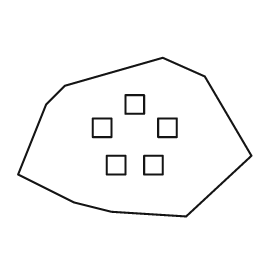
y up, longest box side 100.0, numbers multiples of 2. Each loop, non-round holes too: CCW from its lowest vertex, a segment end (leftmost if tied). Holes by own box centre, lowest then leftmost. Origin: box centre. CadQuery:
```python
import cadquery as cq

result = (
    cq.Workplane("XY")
    .moveTo(22.0, -34.0)
    .lineTo(50.0, -8.0)
    .lineTo(30.0, 26.0)
    .lineTo(12.0, 34.0)
    .lineTo(-30.0, 22.0)
    .lineTo(-38.0, 14.0)
    .lineTo(-50.0, -16.0)
    .lineTo(-26.0, -28.0)
    .lineTo(-10.0, -32.0)
    .close()
    .moveTo(-12.0, -16.0)
    .lineTo(-4.0, -16.0)
    .lineTo(-4.0, -8.0)
    .lineTo(-12.0, -8.0)
    .close()
    .moveTo(4.0, -16.0)
    .lineTo(12.0, -16.0)
    .lineTo(12.0, -8.0)
    .lineTo(4.0, -8.0)
    .close()
    .moveTo(-18.0, 0.0)
    .lineTo(-10.0, 0.0)
    .lineTo(-10.0, 8.0)
    .lineTo(-18.0, 8.0)
    .close()
    .moveTo(10.0, 0.0)
    .lineTo(18.0, 0.0)
    .lineTo(18.0, 8.0)
    .lineTo(10.0, 8.0)
    .close()
    .moveTo(-4.0, 10.0)
    .lineTo(4.0, 10.0)
    .lineTo(4.0, 18.0)
    .lineTo(-4.0, 18.0)
    .close()
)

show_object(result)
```